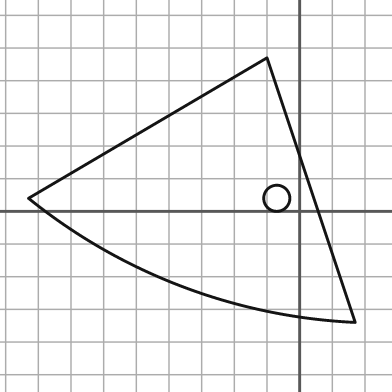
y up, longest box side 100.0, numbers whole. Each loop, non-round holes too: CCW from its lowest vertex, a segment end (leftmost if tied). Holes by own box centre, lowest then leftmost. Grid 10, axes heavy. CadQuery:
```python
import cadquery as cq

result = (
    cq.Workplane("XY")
    .moveTo(17.0, -34.0)
    .lineTo(-10.0, 47.0)
    .lineTo(-83.0, 4.0)
    .threePointArc((-36.0, -23.0), (17.0, -34.0))
    .close()
    .moveTo(-7.0, 4.0)
    .circle(4.0)
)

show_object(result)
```